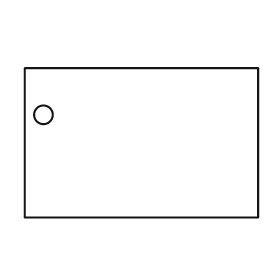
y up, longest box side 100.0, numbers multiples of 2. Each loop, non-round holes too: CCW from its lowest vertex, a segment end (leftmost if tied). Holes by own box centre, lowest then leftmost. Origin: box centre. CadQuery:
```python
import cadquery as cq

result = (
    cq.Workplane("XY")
    .moveTo(-50.0, -32.0)
    .lineTo(50.0, -32.0)
    .lineTo(50.0, 32.0)
    .lineTo(-50.0, 32.0)
    .close()
    .moveTo(-42.0, 12.0)
    .circle(4.0)
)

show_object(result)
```